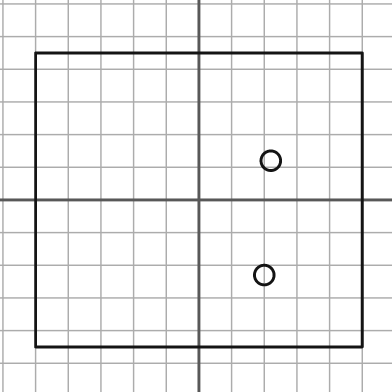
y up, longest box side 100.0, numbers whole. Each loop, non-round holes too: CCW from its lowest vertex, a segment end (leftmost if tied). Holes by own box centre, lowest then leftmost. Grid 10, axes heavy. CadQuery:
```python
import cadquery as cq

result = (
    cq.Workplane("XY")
    .moveTo(-50.0, -45.0)
    .lineTo(50.0, -45.0)
    .lineTo(50.0, 45.0)
    .lineTo(-50.0, 45.0)
    .close()
    .moveTo(20.0, -23.0)
    .circle(3.0)
    .moveTo(22.0, 12.0)
    .circle(3.0)
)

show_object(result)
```